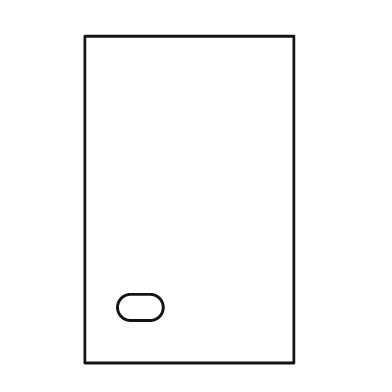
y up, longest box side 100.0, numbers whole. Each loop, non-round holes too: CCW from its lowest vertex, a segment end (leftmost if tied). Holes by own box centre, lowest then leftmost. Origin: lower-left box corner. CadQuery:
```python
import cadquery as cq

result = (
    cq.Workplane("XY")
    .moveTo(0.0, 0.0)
    .lineTo(64.0, 0.0)
    .lineTo(64.0, 100.0)
    .lineTo(0.0, 100.0)
    .close()
    .moveTo(14.0, 13.0)
    .lineTo(20.0, 13.0)
    .threePointArc((24.0, 17.0), (20.0, 21.0))
    .lineTo(14.0, 21.0)
    .threePointArc((10.0, 17.0), (14.0, 13.0))
    .close()
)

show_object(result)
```